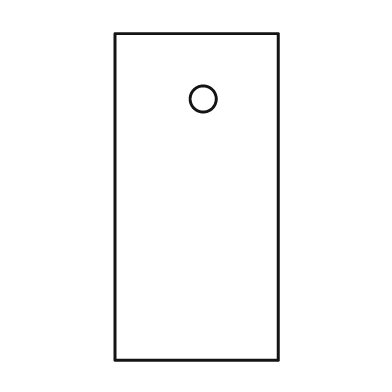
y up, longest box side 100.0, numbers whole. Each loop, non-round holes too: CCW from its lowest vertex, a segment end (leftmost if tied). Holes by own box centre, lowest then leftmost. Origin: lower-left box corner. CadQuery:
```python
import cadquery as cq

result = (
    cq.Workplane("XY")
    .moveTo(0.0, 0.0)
    .lineTo(50.0, 0.0)
    .lineTo(50.0, 100.0)
    .lineTo(0.0, 100.0)
    .close()
    .moveTo(27.0, 80.0)
    .circle(4.0)
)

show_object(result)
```